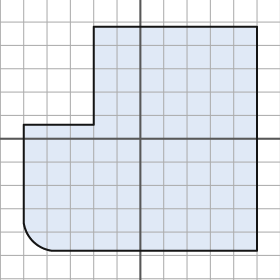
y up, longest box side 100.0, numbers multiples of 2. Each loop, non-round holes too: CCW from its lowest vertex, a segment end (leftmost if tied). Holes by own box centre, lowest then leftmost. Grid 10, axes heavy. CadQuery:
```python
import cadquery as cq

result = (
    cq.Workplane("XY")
    .moveTo(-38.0, -48.0)
    .lineTo(50.0, -48.0)
    .lineTo(50.0, 48.0)
    .lineTo(-20.0, 48.0)
    .lineTo(-20.0, 6.0)
    .lineTo(-50.0, 6.0)
    .lineTo(-50.0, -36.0)
    .threePointArc((-46.0, -44.0), (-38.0, -48.0))
    .close()
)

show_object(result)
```